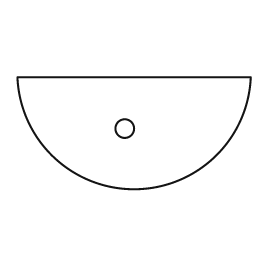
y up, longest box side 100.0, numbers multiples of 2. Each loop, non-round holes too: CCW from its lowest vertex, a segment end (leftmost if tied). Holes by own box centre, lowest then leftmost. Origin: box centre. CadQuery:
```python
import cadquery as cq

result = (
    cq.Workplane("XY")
    .moveTo(-50.0, 24.0)
    .threePointArc((0.0, -24.0), (50.0, 24.0))
    .close()
    .moveTo(-4.0, 2.0)
    .circle(4.0)
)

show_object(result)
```